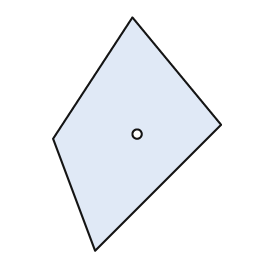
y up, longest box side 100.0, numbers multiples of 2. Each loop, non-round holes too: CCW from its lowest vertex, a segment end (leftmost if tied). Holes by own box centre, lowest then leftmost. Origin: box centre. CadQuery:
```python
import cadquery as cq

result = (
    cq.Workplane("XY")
    .moveTo(-18.0, -50.0)
    .lineTo(36.0, 4.0)
    .lineTo(-2.0, 50.0)
    .lineTo(-36.0, -2.0)
    .close()
    .moveTo(0.0, 0.0)
    .circle(2.0)
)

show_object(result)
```